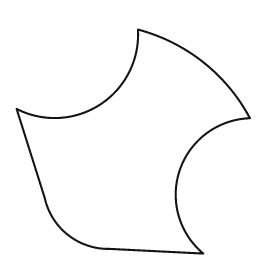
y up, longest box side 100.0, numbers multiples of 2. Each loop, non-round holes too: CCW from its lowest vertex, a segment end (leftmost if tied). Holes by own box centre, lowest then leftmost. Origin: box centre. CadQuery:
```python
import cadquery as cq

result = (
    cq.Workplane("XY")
    .moveTo(30.0, -48.0)
    .threePointArc((20.0, -12.0), (50.0, 10.0))
    .threePointArc((30.0, 34.0), (2.0, 48.0))
    .threePointArc((-14.0, 16.0), (-50.0, 14.0))
    .lineTo(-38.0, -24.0)
    .threePointArc((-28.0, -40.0), (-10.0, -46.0))
    .close()
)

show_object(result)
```